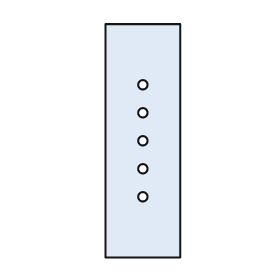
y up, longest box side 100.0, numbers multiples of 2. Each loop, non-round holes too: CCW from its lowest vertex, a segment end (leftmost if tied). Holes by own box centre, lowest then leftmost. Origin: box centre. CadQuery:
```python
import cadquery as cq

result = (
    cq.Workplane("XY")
    .moveTo(-16.0, -50.0)
    .lineTo(16.0, -50.0)
    .lineTo(16.0, 50.0)
    .lineTo(-16.0, 50.0)
    .close()
    .moveTo(0.0, -24.0)
    .circle(2.0)
    .moveTo(0.0, -12.0)
    .circle(2.0)
    .moveTo(0.0, 0.0)
    .circle(2.0)
    .moveTo(0.0, 12.0)
    .circle(2.0)
    .moveTo(0.0, 24.0)
    .circle(2.0)
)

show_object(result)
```